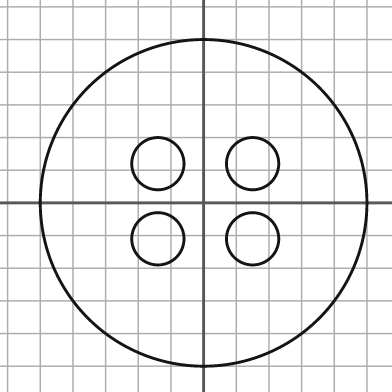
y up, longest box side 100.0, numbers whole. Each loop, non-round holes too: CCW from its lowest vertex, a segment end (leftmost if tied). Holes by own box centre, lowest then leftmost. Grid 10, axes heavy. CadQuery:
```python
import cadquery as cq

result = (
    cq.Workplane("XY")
    .moveTo(0.0, 0.0)
    .circle(50.0)
    .moveTo(-14.0, -11.0)
    .circle(8.0)
    .moveTo(15.0, -11.0)
    .circle(8.0)
    .moveTo(-14.0, 12.0)
    .circle(8.0)
    .moveTo(15.0, 12.0)
    .circle(8.0)
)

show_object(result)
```